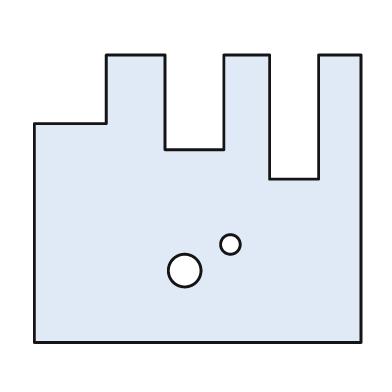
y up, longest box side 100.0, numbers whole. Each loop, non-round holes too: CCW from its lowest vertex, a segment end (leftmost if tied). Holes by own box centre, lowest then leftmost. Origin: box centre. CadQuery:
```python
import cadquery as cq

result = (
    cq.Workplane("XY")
    .moveTo(-50.0, -44.0)
    .lineTo(50.0, -44.0)
    .lineTo(50.0, 44.0)
    .lineTo(37.0, 44.0)
    .lineTo(37.0, 6.0)
    .lineTo(22.0, 6.0)
    .lineTo(22.0, 44.0)
    .lineTo(8.0, 44.0)
    .lineTo(8.0, 15.0)
    .lineTo(-10.0, 15.0)
    .lineTo(-10.0, 44.0)
    .lineTo(-28.0, 44.0)
    .lineTo(-28.0, 23.0)
    .lineTo(-50.0, 23.0)
    .close()
    .moveTo(-4.0, -22.0)
    .circle(5.0)
    .moveTo(10.0, -14.0)
    .circle(3.0)
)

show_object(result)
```